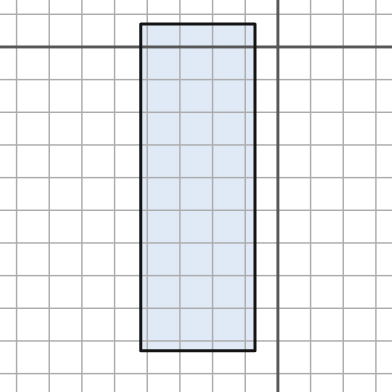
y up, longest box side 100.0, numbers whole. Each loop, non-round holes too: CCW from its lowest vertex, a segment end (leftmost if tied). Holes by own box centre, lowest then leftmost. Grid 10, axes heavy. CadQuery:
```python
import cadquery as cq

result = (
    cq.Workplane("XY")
    .moveTo(-42.0, -93.0)
    .lineTo(-7.0, -93.0)
    .lineTo(-7.0, 7.0)
    .lineTo(-42.0, 7.0)
    .close()
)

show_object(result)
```